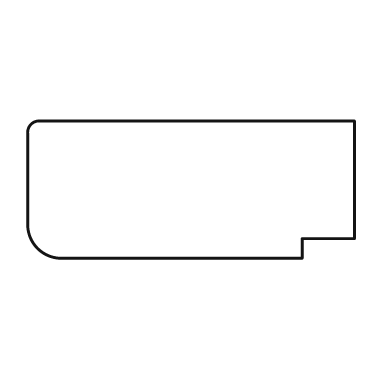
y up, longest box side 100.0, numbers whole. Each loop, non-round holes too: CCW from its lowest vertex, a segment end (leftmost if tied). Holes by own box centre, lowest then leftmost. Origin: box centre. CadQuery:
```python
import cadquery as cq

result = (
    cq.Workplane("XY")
    .moveTo(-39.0, -21.0)
    .lineTo(34.0, -21.0)
    .lineTo(34.0, -15.0)
    .lineTo(50.0, -15.0)
    .lineTo(50.0, 21.0)
    .lineTo(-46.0, 21.0)
    .threePointArc((-49.0, 20.0), (-50.0, 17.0))
    .lineTo(-50.0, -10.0)
    .threePointArc((-47.0, -18.0), (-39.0, -21.0))
    .close()
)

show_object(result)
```